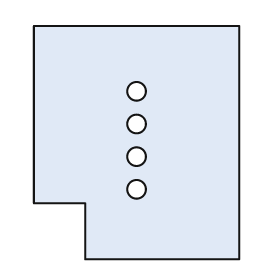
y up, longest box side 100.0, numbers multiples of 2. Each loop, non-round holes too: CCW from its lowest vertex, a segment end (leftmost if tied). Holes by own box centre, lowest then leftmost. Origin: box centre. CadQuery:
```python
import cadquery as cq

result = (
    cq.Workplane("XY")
    .moveTo(-22.0, -50.0)
    .lineTo(44.0, -50.0)
    .lineTo(44.0, 50.0)
    .lineTo(-44.0, 50.0)
    .lineTo(-44.0, -26.0)
    .lineTo(-22.0, -26.0)
    .close()
    .moveTo(0.0, -20.0)
    .circle(4.0)
    .moveTo(0.0, -6.0)
    .circle(4.0)
    .moveTo(0.0, 8.0)
    .circle(4.0)
    .moveTo(0.0, 22.0)
    .circle(4.0)
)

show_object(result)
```